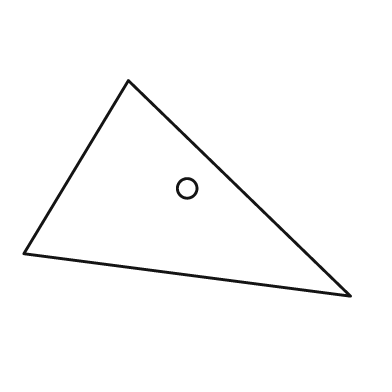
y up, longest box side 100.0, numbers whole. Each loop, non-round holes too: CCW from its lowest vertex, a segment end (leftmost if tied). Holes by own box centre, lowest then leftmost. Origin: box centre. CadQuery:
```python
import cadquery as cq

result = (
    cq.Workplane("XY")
    .moveTo(50.0, -33.0)
    .lineTo(-18.0, 33.0)
    .lineTo(-50.0, -20.0)
    .close()
    .moveTo(0.0, 0.0)
    .circle(3.0)
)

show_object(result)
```